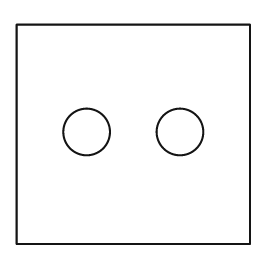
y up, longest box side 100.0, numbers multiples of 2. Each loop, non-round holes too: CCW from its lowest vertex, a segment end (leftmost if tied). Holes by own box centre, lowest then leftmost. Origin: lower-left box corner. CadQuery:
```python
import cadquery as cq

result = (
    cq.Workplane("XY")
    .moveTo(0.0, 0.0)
    .lineTo(100.0, 0.0)
    .lineTo(100.0, 94.0)
    .lineTo(0.0, 94.0)
    .close()
    .moveTo(30.0, 48.0)
    .circle(10.0)
    .moveTo(70.0, 48.0)
    .circle(10.0)
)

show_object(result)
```